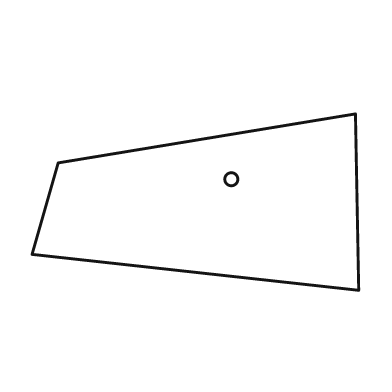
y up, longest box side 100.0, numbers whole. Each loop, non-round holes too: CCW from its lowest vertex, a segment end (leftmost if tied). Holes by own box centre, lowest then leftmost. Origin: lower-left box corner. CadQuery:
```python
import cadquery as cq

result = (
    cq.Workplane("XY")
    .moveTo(100.0, 0.0)
    .lineTo(99.0, 54.0)
    .lineTo(8.0, 39.0)
    .lineTo(0.0, 11.0)
    .close()
    .moveTo(61.0, 34.0)
    .circle(2.0)
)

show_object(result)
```